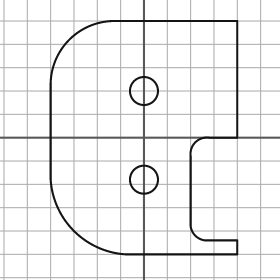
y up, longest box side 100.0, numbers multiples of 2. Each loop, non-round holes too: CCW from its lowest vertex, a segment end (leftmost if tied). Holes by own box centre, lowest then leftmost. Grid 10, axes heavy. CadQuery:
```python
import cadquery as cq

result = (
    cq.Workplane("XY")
    .moveTo(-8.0, -50.0)
    .lineTo(40.0, -50.0)
    .lineTo(40.0, -44.0)
    .lineTo(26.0, -44.0)
    .threePointArc((22.0, -42.0), (20.0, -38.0))
    .lineTo(20.0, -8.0)
    .threePointArc((22.0, -2.0), (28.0, 0.0))
    .lineTo(40.0, 0.0)
    .lineTo(40.0, 50.0)
    .lineTo(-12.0, 50.0)
    .threePointArc((-32.0, 42.0), (-40.0, 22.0))
    .lineTo(-40.0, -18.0)
    .threePointArc((-30.0, -40.0), (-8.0, -50.0))
    .close()
    .moveTo(0.0, -18.0)
    .circle(6.0)
    .moveTo(0.0, 20.0)
    .circle(6.0)
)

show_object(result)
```